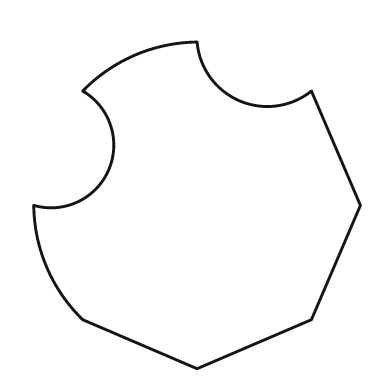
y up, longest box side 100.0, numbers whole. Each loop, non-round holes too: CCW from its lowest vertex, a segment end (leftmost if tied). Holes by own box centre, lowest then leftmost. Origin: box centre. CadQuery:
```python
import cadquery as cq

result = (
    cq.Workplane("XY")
    .moveTo(0.0, -50.0)
    .lineTo(35.0, -35.0)
    .lineTo(50.0, 0.0)
    .lineTo(35.0, 35.0)
    .threePointArc((13.0, 32.0), (0.0, 50.0))
    .threePointArc((-19.0, 46.0), (-35.0, 35.0))
    .threePointArc((-27.0, 11.0), (-50.0, 0.0))
    .threePointArc((-46.0, -19.0), (-35.0, -35.0))
    .close()
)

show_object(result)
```